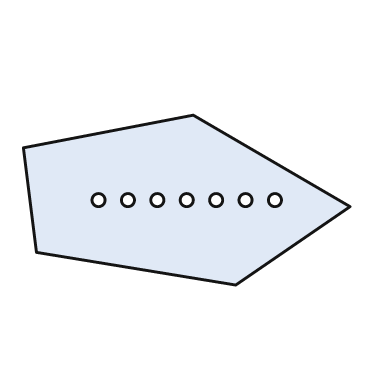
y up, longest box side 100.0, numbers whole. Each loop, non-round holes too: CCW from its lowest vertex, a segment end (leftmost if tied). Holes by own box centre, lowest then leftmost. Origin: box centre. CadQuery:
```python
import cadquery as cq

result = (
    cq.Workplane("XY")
    .moveTo(15.0, -26.0)
    .lineTo(50.0, -2.0)
    .lineTo(2.0, 26.0)
    .lineTo(-50.0, 16.0)
    .lineTo(-46.0, -16.0)
    .close()
    .moveTo(-27.0, 0.0)
    .circle(2.0)
    .moveTo(-18.0, 0.0)
    .circle(2.0)
    .moveTo(-9.0, 0.0)
    .circle(2.0)
    .moveTo(0.0, 0.0)
    .circle(2.0)
    .moveTo(9.0, 0.0)
    .circle(2.0)
    .moveTo(18.0, 0.0)
    .circle(2.0)
    .moveTo(27.0, 0.0)
    .circle(2.0)
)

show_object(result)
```